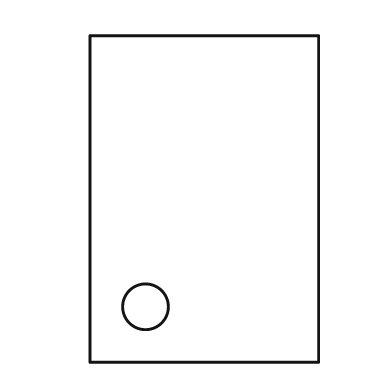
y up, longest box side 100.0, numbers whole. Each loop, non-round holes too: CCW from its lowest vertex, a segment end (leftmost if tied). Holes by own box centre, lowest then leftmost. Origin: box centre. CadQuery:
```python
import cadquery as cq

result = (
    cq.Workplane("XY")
    .moveTo(-35.0, -50.0)
    .lineTo(35.0, -50.0)
    .lineTo(35.0, 50.0)
    .lineTo(-35.0, 50.0)
    .close()
    .moveTo(-18.0, -33.0)
    .circle(7.0)
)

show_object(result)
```